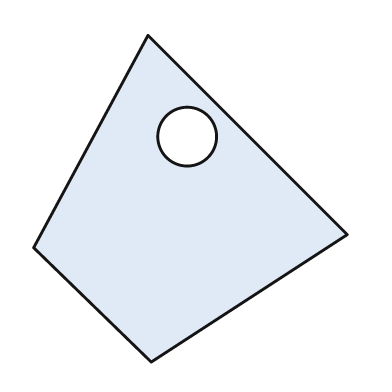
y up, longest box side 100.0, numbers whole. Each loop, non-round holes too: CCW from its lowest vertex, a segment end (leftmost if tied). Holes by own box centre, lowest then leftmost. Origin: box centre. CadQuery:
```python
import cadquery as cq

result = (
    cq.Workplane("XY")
    .moveTo(-12.0, -50.0)
    .lineTo(48.0, -11.0)
    .lineTo(-13.0, 50.0)
    .lineTo(-48.0, -15.0)
    .close()
    .moveTo(-1.0, 19.0)
    .circle(9.0)
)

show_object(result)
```